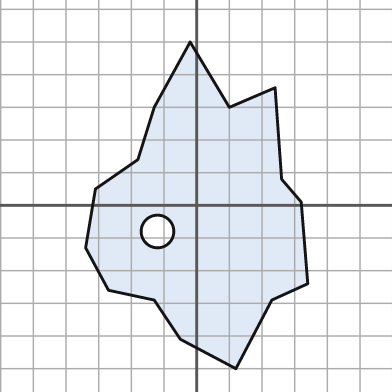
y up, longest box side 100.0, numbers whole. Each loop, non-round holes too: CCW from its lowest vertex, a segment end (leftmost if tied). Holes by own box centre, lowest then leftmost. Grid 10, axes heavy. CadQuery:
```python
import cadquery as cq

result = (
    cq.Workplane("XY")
    .moveTo(12.0, -50.0)
    .lineTo(23.0, -29.0)
    .lineTo(34.0, -24.0)
    .lineTo(32.0, 1.0)
    .lineTo(26.0, 8.0)
    .lineTo(24.0, 36.0)
    .lineTo(10.0, 30.0)
    .lineTo(-2.0, 50.0)
    .lineTo(-13.0, 30.0)
    .lineTo(-18.0, 14.0)
    .lineTo(-31.0, 5.0)
    .lineTo(-34.0, -13.0)
    .lineTo(-27.0, -26.0)
    .lineTo(-13.0, -29.0)
    .lineTo(-5.0, -41.0)
    .close()
    .moveTo(-12.0, -8.0)
    .circle(5.0)
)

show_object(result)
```